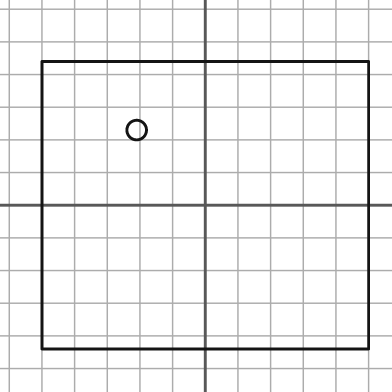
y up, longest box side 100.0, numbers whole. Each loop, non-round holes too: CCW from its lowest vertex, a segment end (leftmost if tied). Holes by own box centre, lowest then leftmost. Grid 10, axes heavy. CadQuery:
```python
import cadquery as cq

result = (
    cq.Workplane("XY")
    .moveTo(-50.0, -44.0)
    .lineTo(50.0, -44.0)
    .lineTo(50.0, 44.0)
    .lineTo(-50.0, 44.0)
    .close()
    .moveTo(-21.0, 23.0)
    .circle(3.0)
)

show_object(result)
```